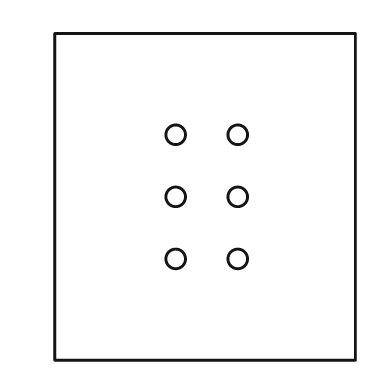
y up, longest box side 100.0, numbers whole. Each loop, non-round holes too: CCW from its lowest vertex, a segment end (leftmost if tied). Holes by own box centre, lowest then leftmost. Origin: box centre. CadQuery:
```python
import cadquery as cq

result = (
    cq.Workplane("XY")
    .moveTo(-46.0, -50.0)
    .lineTo(46.0, -50.0)
    .lineTo(46.0, 50.0)
    .lineTo(-46.0, 50.0)
    .close()
    .moveTo(-9.0, -19.0)
    .circle(3.0)
    .moveTo(10.0, -19.0)
    .circle(3.0)
    .moveTo(-9.0, 0.0)
    .circle(3.0)
    .moveTo(10.0, 0.0)
    .circle(3.0)
    .moveTo(-9.0, 19.0)
    .circle(3.0)
    .moveTo(10.0, 19.0)
    .circle(3.0)
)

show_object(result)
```